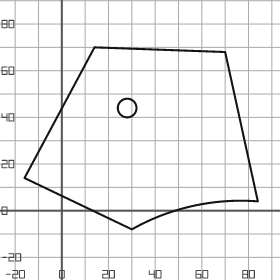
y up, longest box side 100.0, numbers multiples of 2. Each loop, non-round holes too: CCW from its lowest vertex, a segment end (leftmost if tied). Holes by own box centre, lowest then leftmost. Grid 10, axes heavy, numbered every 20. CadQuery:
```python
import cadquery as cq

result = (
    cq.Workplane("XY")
    .moveTo(30.0, -8.0)
    .threePointArc((56.0, 2.0), (84.0, 4.0))
    .lineTo(70.0, 68.0)
    .lineTo(14.0, 70.0)
    .lineTo(-16.0, 14.0)
    .close()
    .moveTo(28.0, 44.0)
    .circle(4.0)
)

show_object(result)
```